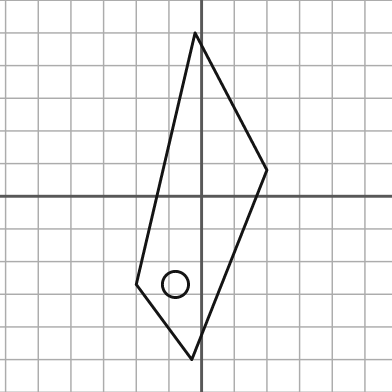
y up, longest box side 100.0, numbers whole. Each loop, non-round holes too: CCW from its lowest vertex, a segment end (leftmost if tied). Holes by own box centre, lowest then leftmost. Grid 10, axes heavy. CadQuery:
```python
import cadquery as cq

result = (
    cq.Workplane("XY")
    .moveTo(-3.0, -50.0)
    .lineTo(20.0, 8.0)
    .lineTo(-2.0, 50.0)
    .lineTo(-20.0, -27.0)
    .close()
    .moveTo(-8.0, -27.0)
    .circle(4.0)
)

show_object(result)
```